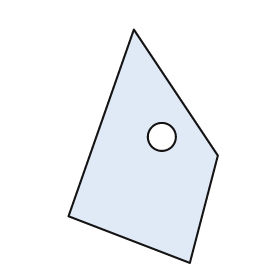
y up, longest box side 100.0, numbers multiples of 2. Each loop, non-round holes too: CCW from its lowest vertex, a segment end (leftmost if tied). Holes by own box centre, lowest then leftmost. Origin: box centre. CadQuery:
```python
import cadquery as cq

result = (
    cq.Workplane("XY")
    .moveTo(20.0, -50.0)
    .lineTo(32.0, -4.0)
    .lineTo(-4.0, 50.0)
    .lineTo(-32.0, -30.0)
    .close()
    .moveTo(8.0, 4.0)
    .circle(6.0)
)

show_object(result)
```